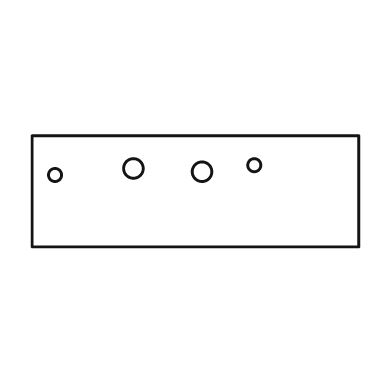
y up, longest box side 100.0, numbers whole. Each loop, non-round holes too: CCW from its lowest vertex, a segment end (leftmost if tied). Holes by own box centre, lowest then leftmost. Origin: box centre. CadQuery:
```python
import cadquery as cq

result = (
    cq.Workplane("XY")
    .moveTo(-50.0, -17.0)
    .lineTo(50.0, -17.0)
    .lineTo(50.0, 17.0)
    .lineTo(-50.0, 17.0)
    .close()
    .moveTo(-43.0, 5.0)
    .circle(2.0)
    .moveTo(2.0, 6.0)
    .circle(3.0)
    .moveTo(-19.0, 7.0)
    .circle(3.0)
    .moveTo(18.0, 8.0)
    .circle(2.0)
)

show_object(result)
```